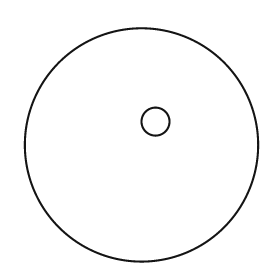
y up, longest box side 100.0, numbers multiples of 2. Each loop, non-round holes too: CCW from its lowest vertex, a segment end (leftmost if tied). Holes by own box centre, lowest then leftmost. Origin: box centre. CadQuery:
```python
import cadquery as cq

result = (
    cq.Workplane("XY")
    .moveTo(0.0, 0.0)
    .circle(50.0)
    .moveTo(6.0, 10.0)
    .circle(6.0)
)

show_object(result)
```